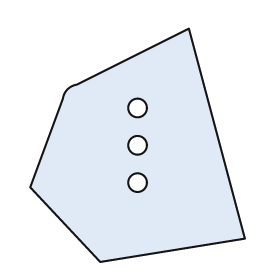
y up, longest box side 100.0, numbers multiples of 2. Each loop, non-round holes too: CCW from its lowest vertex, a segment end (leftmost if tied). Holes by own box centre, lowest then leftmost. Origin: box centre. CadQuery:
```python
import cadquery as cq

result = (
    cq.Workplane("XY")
    .moveTo(-16.0, -50.0)
    .lineTo(46.0, -40.0)
    .lineTo(22.0, 50.0)
    .lineTo(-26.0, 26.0)
    .threePointArc((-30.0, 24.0), (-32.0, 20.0))
    .lineTo(-46.0, -18.0)
    .close()
    .moveTo(0.0, -16.0)
    .circle(4.0)
    .moveTo(0.0, 0.0)
    .circle(4.0)
    .moveTo(0.0, 16.0)
    .circle(4.0)
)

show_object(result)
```